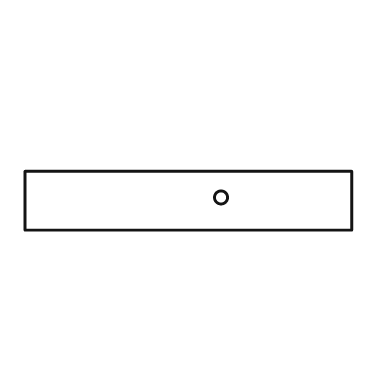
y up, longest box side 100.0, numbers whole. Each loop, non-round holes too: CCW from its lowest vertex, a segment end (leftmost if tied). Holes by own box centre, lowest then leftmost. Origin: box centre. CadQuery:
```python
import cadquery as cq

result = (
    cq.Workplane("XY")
    .moveTo(-50.0, -9.0)
    .lineTo(50.0, -9.0)
    .lineTo(50.0, 9.0)
    .lineTo(-50.0, 9.0)
    .close()
    .moveTo(10.0, 1.0)
    .circle(2.0)
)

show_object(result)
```